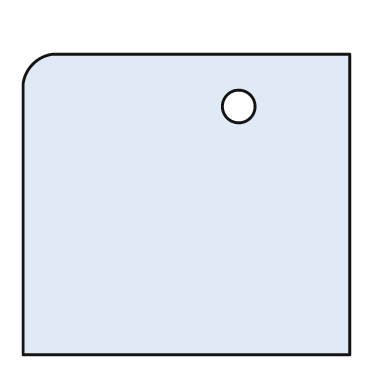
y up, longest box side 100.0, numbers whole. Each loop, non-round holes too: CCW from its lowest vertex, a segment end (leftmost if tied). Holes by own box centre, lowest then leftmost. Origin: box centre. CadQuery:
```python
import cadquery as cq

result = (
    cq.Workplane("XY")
    .moveTo(-50.0, -46.0)
    .lineTo(50.0, -46.0)
    .lineTo(50.0, 46.0)
    .lineTo(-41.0, 46.0)
    .threePointArc((-47.0, 43.0), (-50.0, 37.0))
    .close()
    .moveTo(16.0, 30.0)
    .circle(5.0)
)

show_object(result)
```